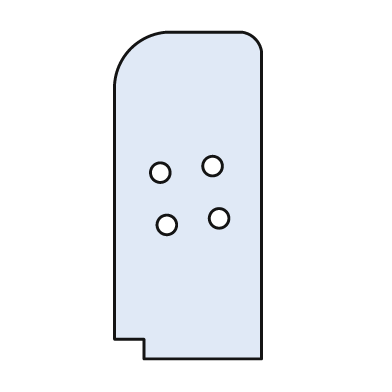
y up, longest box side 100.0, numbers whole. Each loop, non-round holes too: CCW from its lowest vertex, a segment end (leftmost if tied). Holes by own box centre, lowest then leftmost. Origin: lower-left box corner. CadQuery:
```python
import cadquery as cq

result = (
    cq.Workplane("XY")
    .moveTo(9.0, 0.0)
    .lineTo(45.0, 0.0)
    .lineTo(45.0, 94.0)
    .threePointArc((43.0, 98.0), (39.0, 100.0))
    .lineTo(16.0, 100.0)
    .threePointArc((5.0, 95.0), (0.0, 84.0))
    .lineTo(0.0, 6.0)
    .lineTo(9.0, 6.0)
    .close()
    .moveTo(16.0, 41.0)
    .circle(3.0)
    .moveTo(32.0, 43.0)
    .circle(3.0)
    .moveTo(14.0, 57.0)
    .circle(3.0)
    .moveTo(30.0, 59.0)
    .circle(3.0)
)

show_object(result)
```